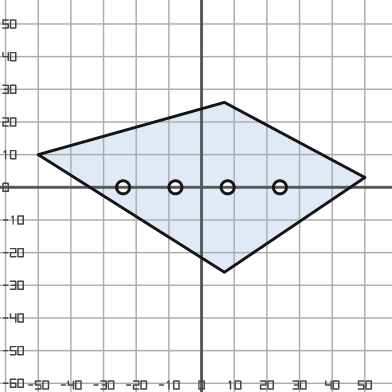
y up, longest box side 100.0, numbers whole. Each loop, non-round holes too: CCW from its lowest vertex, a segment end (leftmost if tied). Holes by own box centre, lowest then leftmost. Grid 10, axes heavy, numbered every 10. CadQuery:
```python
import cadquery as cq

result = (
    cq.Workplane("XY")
    .moveTo(7.0, -26.0)
    .lineTo(50.0, 3.0)
    .lineTo(7.0, 26.0)
    .lineTo(-50.0, 10.0)
    .close()
    .moveTo(-24.0, 0.0)
    .circle(2.0)
    .moveTo(-8.0, 0.0)
    .circle(2.0)
    .moveTo(8.0, 0.0)
    .circle(2.0)
    .moveTo(24.0, 0.0)
    .circle(2.0)
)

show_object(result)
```